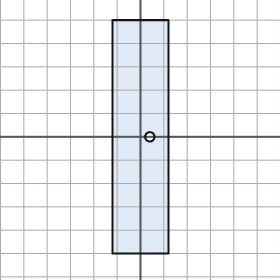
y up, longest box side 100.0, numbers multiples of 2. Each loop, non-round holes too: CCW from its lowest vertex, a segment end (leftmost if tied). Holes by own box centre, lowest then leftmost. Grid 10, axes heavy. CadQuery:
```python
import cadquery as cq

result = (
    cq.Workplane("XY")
    .moveTo(-12.0, -50.0)
    .lineTo(12.0, -50.0)
    .lineTo(12.0, 50.0)
    .lineTo(-12.0, 50.0)
    .close()
    .moveTo(4.0, 0.0)
    .circle(2.0)
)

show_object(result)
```